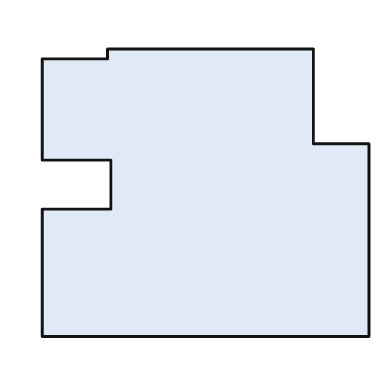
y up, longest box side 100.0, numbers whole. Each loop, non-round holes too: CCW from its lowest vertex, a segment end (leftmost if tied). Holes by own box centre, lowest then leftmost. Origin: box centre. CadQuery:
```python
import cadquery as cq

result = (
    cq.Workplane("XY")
    .moveTo(-50.0, -44.0)
    .lineTo(50.0, -44.0)
    .lineTo(50.0, 15.0)
    .lineTo(33.0, 15.0)
    .lineTo(33.0, 44.0)
    .lineTo(-30.0, 44.0)
    .lineTo(-30.0, 41.0)
    .lineTo(-50.0, 41.0)
    .lineTo(-50.0, 10.0)
    .lineTo(-29.0, 10.0)
    .lineTo(-29.0, -5.0)
    .lineTo(-50.0, -5.0)
    .close()
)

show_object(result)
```